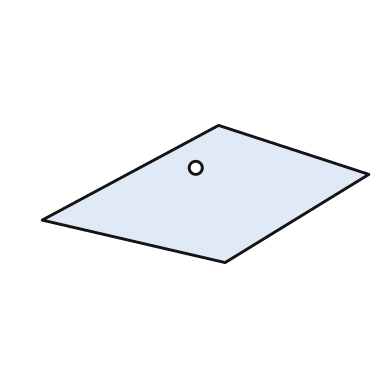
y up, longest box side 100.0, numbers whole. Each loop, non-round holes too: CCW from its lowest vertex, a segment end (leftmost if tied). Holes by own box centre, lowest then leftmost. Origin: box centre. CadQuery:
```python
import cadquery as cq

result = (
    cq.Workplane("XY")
    .moveTo(6.0, -21.0)
    .lineTo(50.0, 6.0)
    .lineTo(4.0, 21.0)
    .lineTo(-50.0, -8.0)
    .close()
    .moveTo(-3.0, 8.0)
    .circle(2.0)
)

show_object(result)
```